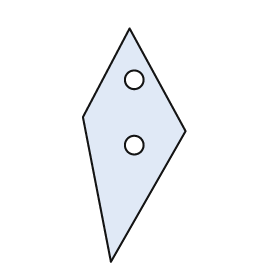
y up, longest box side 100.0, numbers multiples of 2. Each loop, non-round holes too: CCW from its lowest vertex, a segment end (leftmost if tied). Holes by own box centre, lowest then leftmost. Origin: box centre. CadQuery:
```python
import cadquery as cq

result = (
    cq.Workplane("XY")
    .moveTo(-10.0, -50.0)
    .lineTo(22.0, 6.0)
    .lineTo(-2.0, 50.0)
    .lineTo(-22.0, 12.0)
    .close()
    .moveTo(0.0, 0.0)
    .circle(4.0)
    .moveTo(0.0, 28.0)
    .circle(4.0)
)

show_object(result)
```